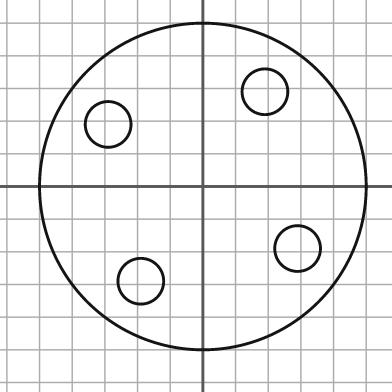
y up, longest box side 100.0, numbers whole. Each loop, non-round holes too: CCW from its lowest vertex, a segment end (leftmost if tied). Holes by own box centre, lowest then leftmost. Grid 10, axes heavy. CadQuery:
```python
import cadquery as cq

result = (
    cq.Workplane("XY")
    .moveTo(0.0, 0.0)
    .circle(50.0)
    .moveTo(-19.0, -29.0)
    .circle(7.0)
    .moveTo(29.0, -19.0)
    .circle(7.0)
    .moveTo(-29.0, 19.0)
    .circle(7.0)
    .moveTo(19.0, 29.0)
    .circle(7.0)
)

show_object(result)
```